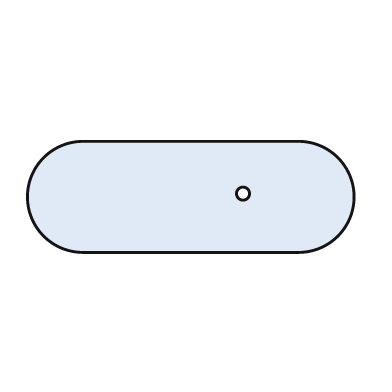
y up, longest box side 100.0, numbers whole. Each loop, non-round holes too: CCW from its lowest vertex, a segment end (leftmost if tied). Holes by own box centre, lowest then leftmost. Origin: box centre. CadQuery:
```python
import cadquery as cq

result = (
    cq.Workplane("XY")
    .moveTo(-33.0, -17.0)
    .lineTo(33.0, -17.0)
    .threePointArc((50.0, 0.0), (33.0, 17.0))
    .lineTo(-33.0, 17.0)
    .threePointArc((-50.0, 0.0), (-33.0, -17.0))
    .close()
    .moveTo(16.0, 1.0)
    .circle(2.0)
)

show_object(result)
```